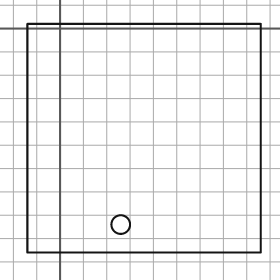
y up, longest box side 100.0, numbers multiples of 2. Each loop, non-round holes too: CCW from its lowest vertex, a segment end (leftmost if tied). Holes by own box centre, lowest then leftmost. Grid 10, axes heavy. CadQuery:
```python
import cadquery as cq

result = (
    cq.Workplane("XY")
    .moveTo(-14.0, -96.0)
    .lineTo(86.0, -96.0)
    .lineTo(86.0, 2.0)
    .lineTo(-14.0, 2.0)
    .close()
    .moveTo(26.0, -84.0)
    .circle(4.0)
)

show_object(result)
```